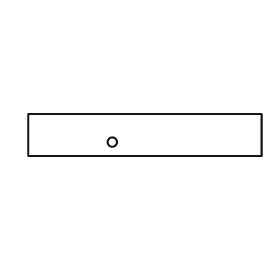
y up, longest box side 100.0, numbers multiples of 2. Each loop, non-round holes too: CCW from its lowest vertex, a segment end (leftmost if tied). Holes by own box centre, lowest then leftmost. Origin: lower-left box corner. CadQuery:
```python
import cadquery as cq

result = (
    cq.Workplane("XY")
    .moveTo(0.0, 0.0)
    .lineTo(100.0, 0.0)
    .lineTo(100.0, 18.0)
    .lineTo(0.0, 18.0)
    .close()
    .moveTo(36.0, 6.0)
    .circle(2.0)
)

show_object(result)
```